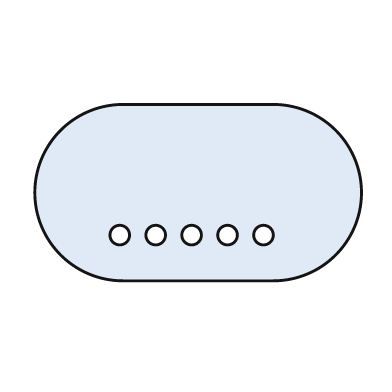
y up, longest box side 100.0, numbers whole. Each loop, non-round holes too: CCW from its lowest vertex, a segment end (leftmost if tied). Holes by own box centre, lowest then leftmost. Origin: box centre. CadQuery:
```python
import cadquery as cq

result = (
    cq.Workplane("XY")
    .moveTo(-23.0, -27.0)
    .lineTo(23.0, -27.0)
    .threePointArc((50.0, 0.0), (23.0, 27.0))
    .lineTo(-23.0, 27.0)
    .threePointArc((-50.0, 0.0), (-23.0, -27.0))
    .close()
    .moveTo(-24.0, -13.0)
    .circle(3.0)
    .moveTo(-13.0, -13.0)
    .circle(3.0)
    .moveTo(-2.0, -13.0)
    .circle(3.0)
    .moveTo(9.0, -13.0)
    .circle(3.0)
    .moveTo(20.0, -13.0)
    .circle(3.0)
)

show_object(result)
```